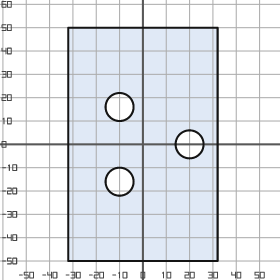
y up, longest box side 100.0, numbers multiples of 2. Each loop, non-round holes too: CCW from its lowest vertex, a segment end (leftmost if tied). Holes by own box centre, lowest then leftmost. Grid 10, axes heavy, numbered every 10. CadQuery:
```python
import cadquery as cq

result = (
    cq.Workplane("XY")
    .moveTo(-32.0, -50.0)
    .lineTo(32.0, -50.0)
    .lineTo(32.0, 50.0)
    .lineTo(-32.0, 50.0)
    .close()
    .moveTo(-10.0, -16.0)
    .circle(6.0)
    .moveTo(20.0, 0.0)
    .circle(6.0)
    .moveTo(-10.0, 16.0)
    .circle(6.0)
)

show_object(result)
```